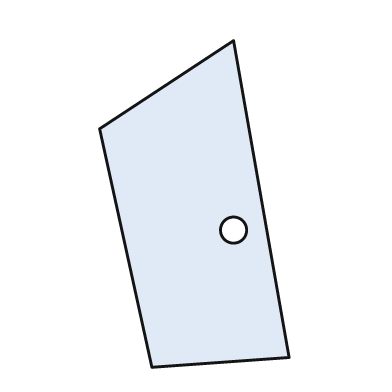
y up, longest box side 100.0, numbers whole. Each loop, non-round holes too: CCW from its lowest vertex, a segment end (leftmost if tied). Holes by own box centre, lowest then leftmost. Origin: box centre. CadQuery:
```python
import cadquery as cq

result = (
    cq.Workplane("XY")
    .moveTo(-13.0, -50.0)
    .lineTo(29.0, -47.0)
    .lineTo(12.0, 50.0)
    .lineTo(-29.0, 23.0)
    .close()
    .moveTo(12.0, -8.0)
    .circle(4.0)
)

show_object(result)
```